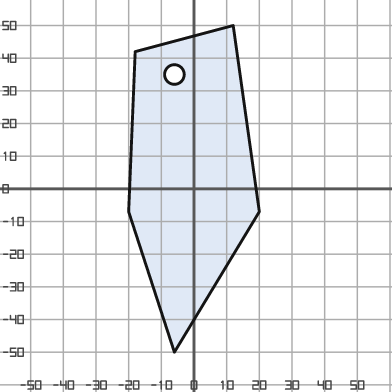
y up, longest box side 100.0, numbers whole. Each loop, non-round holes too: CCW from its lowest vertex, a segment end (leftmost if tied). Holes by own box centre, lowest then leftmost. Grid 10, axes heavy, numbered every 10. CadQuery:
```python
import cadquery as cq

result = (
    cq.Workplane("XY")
    .moveTo(-6.0, -50.0)
    .lineTo(20.0, -7.0)
    .lineTo(12.0, 50.0)
    .lineTo(-18.0, 42.0)
    .lineTo(-20.0, -7.0)
    .close()
    .moveTo(-6.0, 35.0)
    .circle(3.0)
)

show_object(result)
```